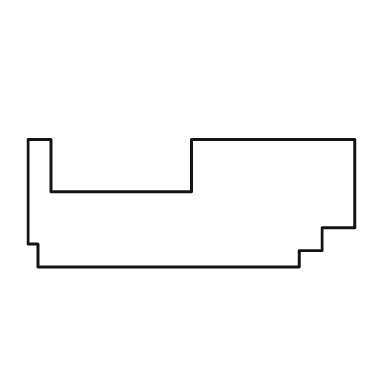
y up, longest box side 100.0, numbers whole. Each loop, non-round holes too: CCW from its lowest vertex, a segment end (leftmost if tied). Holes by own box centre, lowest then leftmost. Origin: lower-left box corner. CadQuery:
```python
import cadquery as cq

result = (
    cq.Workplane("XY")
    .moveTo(3.0, 0.0)
    .lineTo(83.0, 0.0)
    .lineTo(83.0, 5.0)
    .lineTo(90.0, 5.0)
    .lineTo(90.0, 12.0)
    .lineTo(100.0, 12.0)
    .lineTo(100.0, 39.0)
    .lineTo(50.0, 39.0)
    .lineTo(50.0, 23.0)
    .lineTo(7.0, 23.0)
    .lineTo(7.0, 39.0)
    .lineTo(0.0, 39.0)
    .lineTo(0.0, 7.0)
    .lineTo(3.0, 7.0)
    .close()
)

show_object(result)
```